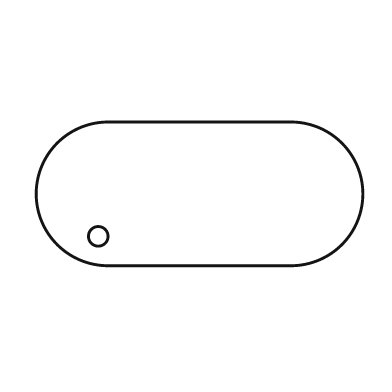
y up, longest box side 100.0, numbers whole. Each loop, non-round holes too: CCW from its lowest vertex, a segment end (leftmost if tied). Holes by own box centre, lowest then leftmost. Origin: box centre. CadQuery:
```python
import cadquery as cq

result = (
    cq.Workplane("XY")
    .moveTo(-28.0, -22.0)
    .lineTo(28.0, -22.0)
    .threePointArc((50.0, 0.0), (28.0, 22.0))
    .lineTo(-28.0, 22.0)
    .threePointArc((-50.0, 0.0), (-28.0, -22.0))
    .close()
    .moveTo(-31.0, -13.0)
    .circle(3.0)
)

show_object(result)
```